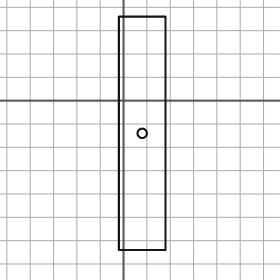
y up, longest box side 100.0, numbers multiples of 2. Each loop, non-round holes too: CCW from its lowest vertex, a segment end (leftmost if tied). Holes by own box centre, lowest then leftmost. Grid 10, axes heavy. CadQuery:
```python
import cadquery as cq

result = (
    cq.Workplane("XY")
    .moveTo(-2.0, -64.0)
    .lineTo(18.0, -64.0)
    .lineTo(18.0, 36.0)
    .lineTo(-2.0, 36.0)
    .close()
    .moveTo(8.0, -14.0)
    .circle(2.0)
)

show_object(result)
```